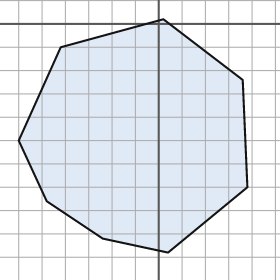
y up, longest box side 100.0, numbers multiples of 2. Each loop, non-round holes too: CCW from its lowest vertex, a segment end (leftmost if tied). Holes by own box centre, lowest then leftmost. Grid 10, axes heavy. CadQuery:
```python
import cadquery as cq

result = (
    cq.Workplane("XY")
    .moveTo(4.0, -98.0)
    .lineTo(38.0, -70.0)
    .lineTo(36.0, -24.0)
    .lineTo(2.0, 2.0)
    .lineTo(-42.0, -10.0)
    .lineTo(-60.0, -50.0)
    .lineTo(-48.0, -76.0)
    .lineTo(-24.0, -92.0)
    .close()
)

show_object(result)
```